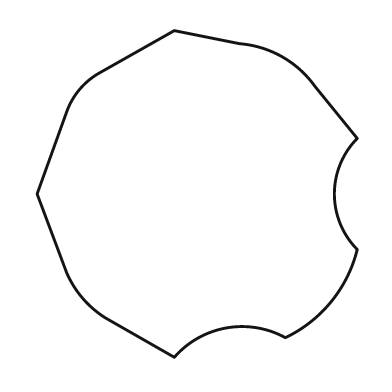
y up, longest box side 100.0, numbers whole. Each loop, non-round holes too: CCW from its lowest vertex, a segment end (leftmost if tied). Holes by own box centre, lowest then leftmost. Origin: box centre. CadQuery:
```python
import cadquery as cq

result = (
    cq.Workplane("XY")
    .moveTo(-7.0, -50.0)
    .threePointArc((9.0, -41.0), (27.0, -44.0))
    .threePointArc((41.0, -33.0), (49.0, -17.0))
    .threePointArc((42.0, 0.0), (49.0, 17.0))
    .lineTo(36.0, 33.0)
    .threePointArc((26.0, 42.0), (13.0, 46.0))
    .lineTo(-7.0, 50.0)
    .lineTo(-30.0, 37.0)
    .threePointArc((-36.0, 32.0), (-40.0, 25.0))
    .lineTo(-49.0, 0.0)
    .lineTo(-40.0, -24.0)
    .threePointArc((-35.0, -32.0), (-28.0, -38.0))
    .close()
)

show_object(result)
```